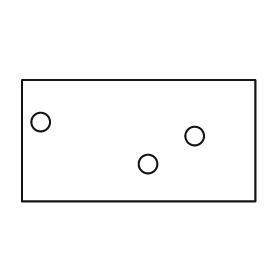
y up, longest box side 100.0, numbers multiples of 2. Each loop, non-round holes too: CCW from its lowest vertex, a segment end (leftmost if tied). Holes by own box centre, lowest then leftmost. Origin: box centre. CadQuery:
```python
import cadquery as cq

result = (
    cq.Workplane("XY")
    .moveTo(-50.0, -26.0)
    .lineTo(50.0, -26.0)
    .lineTo(50.0, 26.0)
    .lineTo(-50.0, 26.0)
    .close()
    .moveTo(4.0, -10.0)
    .circle(4.0)
    .moveTo(24.0, 2.0)
    .circle(4.0)
    .moveTo(-42.0, 8.0)
    .circle(4.0)
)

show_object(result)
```